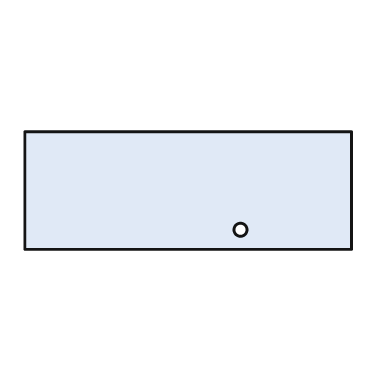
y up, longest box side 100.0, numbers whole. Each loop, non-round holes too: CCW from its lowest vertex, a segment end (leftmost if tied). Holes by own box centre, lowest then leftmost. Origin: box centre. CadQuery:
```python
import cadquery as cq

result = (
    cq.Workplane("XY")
    .moveTo(-50.0, -18.0)
    .lineTo(50.0, -18.0)
    .lineTo(50.0, 18.0)
    .lineTo(-50.0, 18.0)
    .close()
    .moveTo(16.0, -12.0)
    .circle(2.0)
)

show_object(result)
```